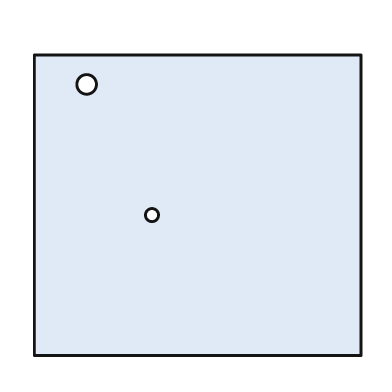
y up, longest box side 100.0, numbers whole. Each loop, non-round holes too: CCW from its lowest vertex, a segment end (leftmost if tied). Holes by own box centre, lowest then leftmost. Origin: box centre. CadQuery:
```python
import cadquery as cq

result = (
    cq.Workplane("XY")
    .moveTo(-50.0, -46.0)
    .lineTo(50.0, -46.0)
    .lineTo(50.0, 46.0)
    .lineTo(-50.0, 46.0)
    .close()
    .moveTo(-14.0, -3.0)
    .circle(2.0)
    .moveTo(-34.0, 37.0)
    .circle(3.0)
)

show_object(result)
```